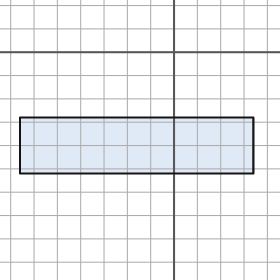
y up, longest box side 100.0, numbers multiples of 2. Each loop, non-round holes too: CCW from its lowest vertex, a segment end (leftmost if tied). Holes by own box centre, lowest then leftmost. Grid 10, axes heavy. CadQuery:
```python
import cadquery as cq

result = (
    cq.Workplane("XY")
    .moveTo(-66.0, -52.0)
    .lineTo(34.0, -52.0)
    .lineTo(34.0, -28.0)
    .lineTo(-66.0, -28.0)
    .close()
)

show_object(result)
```